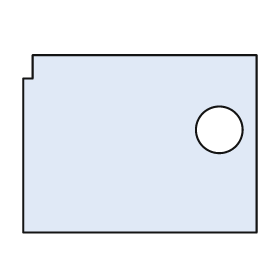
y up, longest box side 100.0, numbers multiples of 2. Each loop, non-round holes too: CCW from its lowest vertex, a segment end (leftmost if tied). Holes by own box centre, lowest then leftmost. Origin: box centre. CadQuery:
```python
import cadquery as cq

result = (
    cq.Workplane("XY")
    .moveTo(-50.0, -38.0)
    .lineTo(50.0, -38.0)
    .lineTo(50.0, 38.0)
    .lineTo(-46.0, 38.0)
    .lineTo(-46.0, 28.0)
    .lineTo(-50.0, 28.0)
    .close()
    .moveTo(34.0, 6.0)
    .circle(10.0)
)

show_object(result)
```